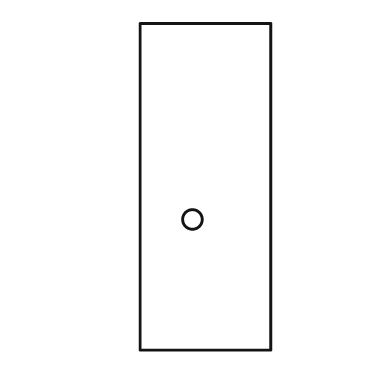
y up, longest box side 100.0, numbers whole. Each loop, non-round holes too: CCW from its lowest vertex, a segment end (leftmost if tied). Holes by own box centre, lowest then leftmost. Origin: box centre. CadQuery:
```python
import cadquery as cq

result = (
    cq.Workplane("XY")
    .moveTo(-20.0, -50.0)
    .lineTo(20.0, -50.0)
    .lineTo(20.0, 50.0)
    .lineTo(-20.0, 50.0)
    .close()
    .moveTo(-4.0, -10.0)
    .circle(3.0)
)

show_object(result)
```